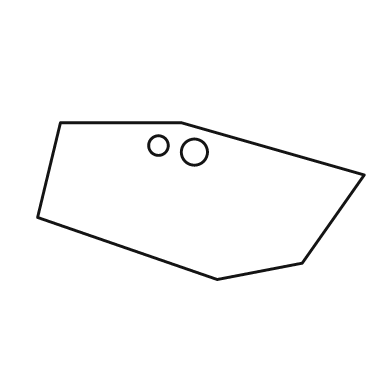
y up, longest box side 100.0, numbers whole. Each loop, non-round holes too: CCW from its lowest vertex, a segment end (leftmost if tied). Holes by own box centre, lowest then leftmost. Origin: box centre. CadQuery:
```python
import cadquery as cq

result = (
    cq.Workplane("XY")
    .moveTo(5.0, -24.0)
    .lineTo(31.0, -19.0)
    .lineTo(50.0, 8.0)
    .lineTo(-6.0, 24.0)
    .lineTo(-43.0, 24.0)
    .lineTo(-50.0, -5.0)
    .close()
    .moveTo(-2.0, 15.0)
    .circle(4.0)
    .moveTo(-13.0, 17.0)
    .circle(3.0)
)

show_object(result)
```